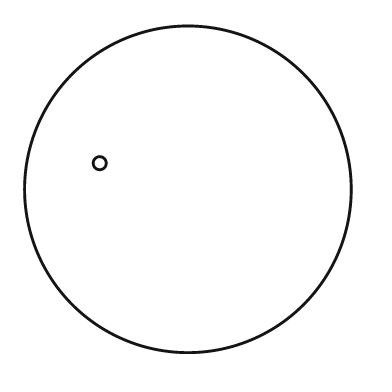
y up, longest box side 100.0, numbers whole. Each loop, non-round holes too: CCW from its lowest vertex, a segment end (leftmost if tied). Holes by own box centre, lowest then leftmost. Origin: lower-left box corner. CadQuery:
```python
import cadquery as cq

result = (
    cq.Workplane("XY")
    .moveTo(50.0, 50.0)
    .circle(50.0)
    .moveTo(23.0, 58.0)
    .circle(2.0)
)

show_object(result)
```